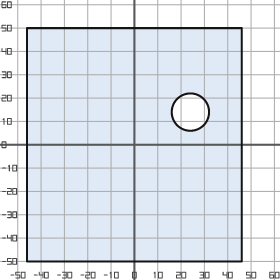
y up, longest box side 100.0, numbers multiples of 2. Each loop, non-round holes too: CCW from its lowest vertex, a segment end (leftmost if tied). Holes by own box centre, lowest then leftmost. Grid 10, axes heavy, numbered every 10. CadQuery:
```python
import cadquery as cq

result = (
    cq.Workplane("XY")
    .moveTo(-46.0, -50.0)
    .lineTo(46.0, -50.0)
    .lineTo(46.0, 50.0)
    .lineTo(-46.0, 50.0)
    .close()
    .moveTo(24.0, 14.0)
    .circle(8.0)
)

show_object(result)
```